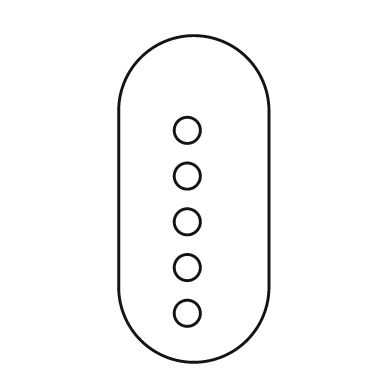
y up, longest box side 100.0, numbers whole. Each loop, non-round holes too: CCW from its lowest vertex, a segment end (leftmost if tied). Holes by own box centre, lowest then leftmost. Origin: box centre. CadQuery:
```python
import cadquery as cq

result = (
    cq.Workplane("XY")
    .moveTo(-23.0, -27.0)
    .threePointArc((0.0, -50.0), (23.0, -27.0))
    .lineTo(23.0, 27.0)
    .threePointArc((0.0, 50.0), (-23.0, 27.0))
    .close()
    .moveTo(-2.0, -35.0)
    .circle(4.0)
    .moveTo(-2.0, -21.0)
    .circle(4.0)
    .moveTo(-2.0, -7.0)
    .circle(4.0)
    .moveTo(-2.0, 7.0)
    .circle(4.0)
    .moveTo(-2.0, 21.0)
    .circle(4.0)
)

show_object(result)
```